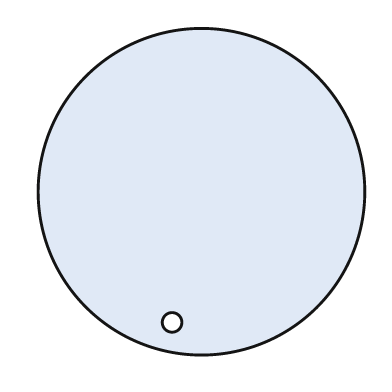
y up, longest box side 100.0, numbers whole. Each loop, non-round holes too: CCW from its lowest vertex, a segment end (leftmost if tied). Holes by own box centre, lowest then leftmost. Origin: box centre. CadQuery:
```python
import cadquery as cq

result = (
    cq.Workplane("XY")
    .moveTo(0.0, 0.0)
    .circle(50.0)
    .moveTo(-9.0, -40.0)
    .circle(3.0)
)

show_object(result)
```